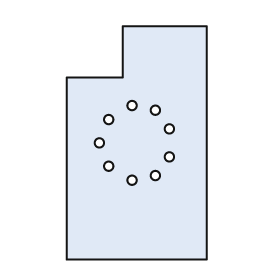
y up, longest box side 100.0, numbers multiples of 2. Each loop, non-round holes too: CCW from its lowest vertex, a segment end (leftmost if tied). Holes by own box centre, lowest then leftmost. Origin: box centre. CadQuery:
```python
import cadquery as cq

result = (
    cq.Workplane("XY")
    .moveTo(-30.0, -50.0)
    .lineTo(30.0, -50.0)
    .lineTo(30.0, 50.0)
    .lineTo(-6.0, 50.0)
    .lineTo(-6.0, 28.0)
    .lineTo(-30.0, 28.0)
    .close()
    .moveTo(-2.0, -16.0)
    .circle(2.0)
    .moveTo(8.0, -14.0)
    .circle(2.0)
    .moveTo(-12.0, -10.0)
    .circle(2.0)
    .moveTo(14.0, -6.0)
    .circle(2.0)
    .moveTo(-16.0, 0.0)
    .circle(2.0)
    .moveTo(14.0, 6.0)
    .circle(2.0)
    .moveTo(-12.0, 10.0)
    .circle(2.0)
    .moveTo(8.0, 14.0)
    .circle(2.0)
    .moveTo(-2.0, 16.0)
    .circle(2.0)
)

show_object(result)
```